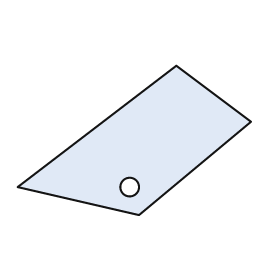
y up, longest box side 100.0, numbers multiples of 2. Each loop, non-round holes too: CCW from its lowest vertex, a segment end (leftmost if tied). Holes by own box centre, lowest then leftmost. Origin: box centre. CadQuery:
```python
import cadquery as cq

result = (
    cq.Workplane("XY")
    .moveTo(2.0, -32.0)
    .lineTo(50.0, 8.0)
    .lineTo(18.0, 32.0)
    .lineTo(-50.0, -20.0)
    .close()
    .moveTo(-2.0, -20.0)
    .circle(4.0)
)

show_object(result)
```